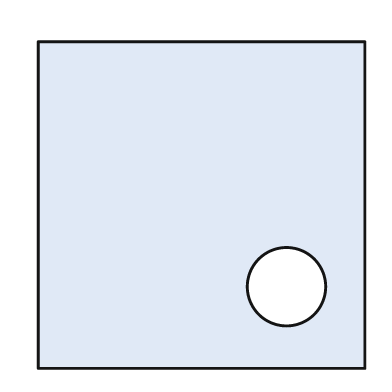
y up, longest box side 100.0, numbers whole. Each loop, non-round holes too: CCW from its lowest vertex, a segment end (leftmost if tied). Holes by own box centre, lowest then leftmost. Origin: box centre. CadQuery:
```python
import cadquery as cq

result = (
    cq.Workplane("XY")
    .moveTo(-50.0, -50.0)
    .lineTo(50.0, -50.0)
    .lineTo(50.0, 50.0)
    .lineTo(-50.0, 50.0)
    .close()
    .moveTo(26.0, -25.0)
    .circle(12.0)
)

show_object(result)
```